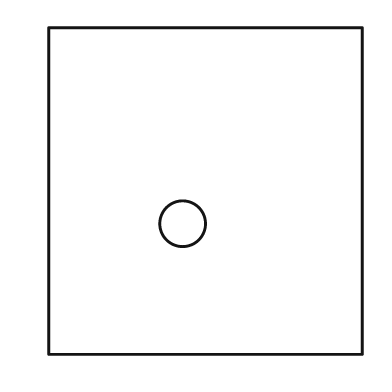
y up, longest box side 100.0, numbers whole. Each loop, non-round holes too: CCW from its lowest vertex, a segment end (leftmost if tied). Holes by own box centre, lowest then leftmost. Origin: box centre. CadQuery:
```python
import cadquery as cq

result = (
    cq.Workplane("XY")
    .moveTo(-48.0, -50.0)
    .lineTo(48.0, -50.0)
    .lineTo(48.0, 50.0)
    .lineTo(-48.0, 50.0)
    .close()
    .moveTo(-7.0, -10.0)
    .circle(7.0)
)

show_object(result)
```